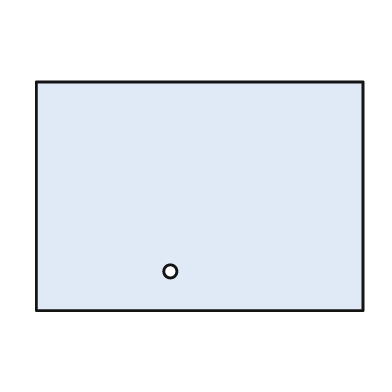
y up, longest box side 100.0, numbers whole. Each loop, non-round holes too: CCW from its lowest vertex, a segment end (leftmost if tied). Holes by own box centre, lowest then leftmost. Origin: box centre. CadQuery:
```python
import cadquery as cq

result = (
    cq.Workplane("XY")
    .moveTo(-50.0, -35.0)
    .lineTo(50.0, -35.0)
    .lineTo(50.0, 35.0)
    .lineTo(-50.0, 35.0)
    .close()
    .moveTo(-9.0, -23.0)
    .circle(2.0)
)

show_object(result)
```